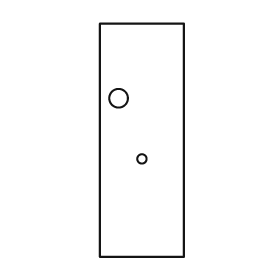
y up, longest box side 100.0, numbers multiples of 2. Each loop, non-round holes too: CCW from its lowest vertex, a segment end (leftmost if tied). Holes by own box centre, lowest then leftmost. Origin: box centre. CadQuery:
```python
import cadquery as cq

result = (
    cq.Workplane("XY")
    .moveTo(-18.0, -50.0)
    .lineTo(18.0, -50.0)
    .lineTo(18.0, 50.0)
    .lineTo(-18.0, 50.0)
    .close()
    .moveTo(0.0, -8.0)
    .circle(2.0)
    .moveTo(-10.0, 18.0)
    .circle(4.0)
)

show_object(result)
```